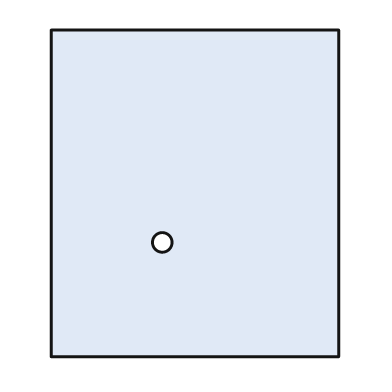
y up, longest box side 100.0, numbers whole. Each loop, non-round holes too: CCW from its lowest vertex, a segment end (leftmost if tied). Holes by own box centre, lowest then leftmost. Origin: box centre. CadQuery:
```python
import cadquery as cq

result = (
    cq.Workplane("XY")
    .moveTo(-44.0, -50.0)
    .lineTo(44.0, -50.0)
    .lineTo(44.0, 50.0)
    .lineTo(-44.0, 50.0)
    .close()
    .moveTo(-10.0, -15.0)
    .circle(3.0)
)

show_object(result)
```